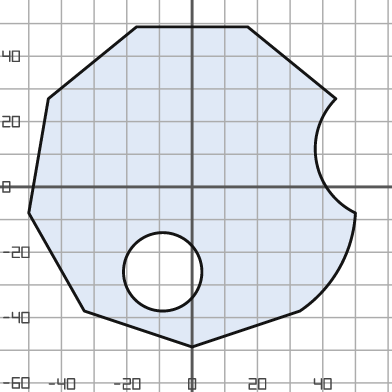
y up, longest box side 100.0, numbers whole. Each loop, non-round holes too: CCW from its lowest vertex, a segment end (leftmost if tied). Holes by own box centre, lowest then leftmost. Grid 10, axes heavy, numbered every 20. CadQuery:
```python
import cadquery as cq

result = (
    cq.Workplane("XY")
    .moveTo(0.0, -49.0)
    .lineTo(33.0, -38.0)
    .threePointArc((45.0, -25.0), (50.0, -8.0))
    .threePointArc((38.0, 8.0), (44.0, 27.0))
    .lineTo(17.0, 49.0)
    .lineTo(-17.0, 49.0)
    .lineTo(-44.0, 27.0)
    .lineTo(-50.0, -8.0)
    .lineTo(-33.0, -38.0)
    .close()
    .moveTo(-9.0, -26.0)
    .circle(12.0)
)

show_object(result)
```